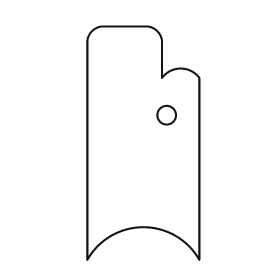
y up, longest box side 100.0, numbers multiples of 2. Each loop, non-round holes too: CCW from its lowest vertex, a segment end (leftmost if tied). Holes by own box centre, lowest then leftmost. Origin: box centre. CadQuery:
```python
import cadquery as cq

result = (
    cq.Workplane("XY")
    .moveTo(-24.0, -50.0)
    .threePointArc((0.0, -36.0), (24.0, -50.0))
    .lineTo(24.0, 28.0)
    .threePointArc((16.0, 32.0), (8.0, 28.0))
    .lineTo(8.0, 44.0)
    .threePointArc((6.0, 48.0), (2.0, 50.0))
    .lineTo(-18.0, 50.0)
    .threePointArc((-22.0, 48.0), (-24.0, 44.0))
    .close()
    .moveTo(10.0, 12.0)
    .circle(4.0)
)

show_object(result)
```